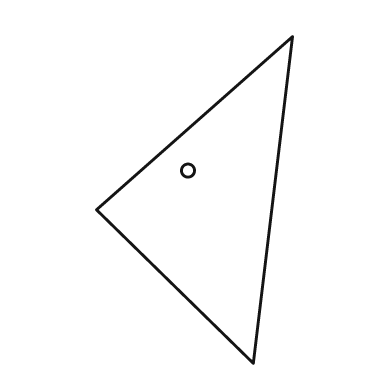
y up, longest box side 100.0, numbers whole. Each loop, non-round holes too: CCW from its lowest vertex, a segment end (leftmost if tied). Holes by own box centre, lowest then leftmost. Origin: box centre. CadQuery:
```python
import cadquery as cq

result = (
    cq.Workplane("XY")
    .moveTo(18.0, -50.0)
    .lineTo(30.0, 50.0)
    .lineTo(-30.0, -3.0)
    .close()
    .moveTo(-2.0, 9.0)
    .circle(2.0)
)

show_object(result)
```